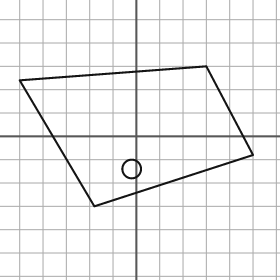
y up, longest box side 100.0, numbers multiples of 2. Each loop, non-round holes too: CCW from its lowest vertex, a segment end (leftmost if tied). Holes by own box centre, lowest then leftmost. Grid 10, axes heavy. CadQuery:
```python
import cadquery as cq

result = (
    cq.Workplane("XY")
    .moveTo(-18.0, -30.0)
    .lineTo(50.0, -8.0)
    .lineTo(30.0, 30.0)
    .lineTo(-50.0, 24.0)
    .close()
    .moveTo(-2.0, -14.0)
    .circle(4.0)
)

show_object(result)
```